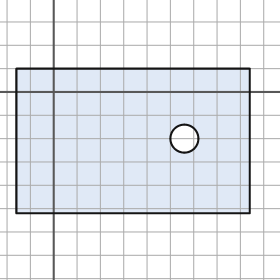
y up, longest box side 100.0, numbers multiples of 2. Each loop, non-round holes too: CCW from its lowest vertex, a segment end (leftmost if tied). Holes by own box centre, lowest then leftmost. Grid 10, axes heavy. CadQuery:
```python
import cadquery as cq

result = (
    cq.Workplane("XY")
    .moveTo(-16.0, -52.0)
    .lineTo(84.0, -52.0)
    .lineTo(84.0, 10.0)
    .lineTo(-16.0, 10.0)
    .close()
    .moveTo(56.0, -20.0)
    .circle(6.0)
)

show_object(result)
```